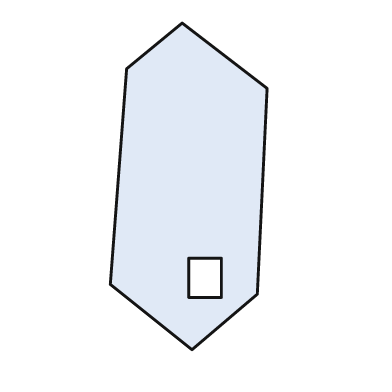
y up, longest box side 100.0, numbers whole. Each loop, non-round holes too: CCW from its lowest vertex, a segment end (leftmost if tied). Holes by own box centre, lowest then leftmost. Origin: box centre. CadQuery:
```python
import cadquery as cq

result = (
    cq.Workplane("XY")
    .moveTo(1.0, -50.0)
    .lineTo(21.0, -33.0)
    .lineTo(24.0, 30.0)
    .lineTo(-2.0, 50.0)
    .lineTo(-19.0, 36.0)
    .lineTo(-24.0, -30.0)
    .close()
    .moveTo(0.0, -34.0)
    .lineTo(10.0, -34.0)
    .lineTo(10.0, -22.0)
    .lineTo(0.0, -22.0)
    .close()
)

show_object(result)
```